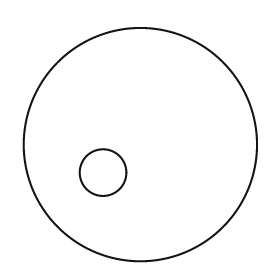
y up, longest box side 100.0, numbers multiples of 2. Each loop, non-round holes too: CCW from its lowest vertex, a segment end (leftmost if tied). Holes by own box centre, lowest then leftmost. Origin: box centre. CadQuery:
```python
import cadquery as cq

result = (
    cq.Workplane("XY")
    .moveTo(0.0, 0.0)
    .circle(50.0)
    .moveTo(-16.0, -12.0)
    .circle(10.0)
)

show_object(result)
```